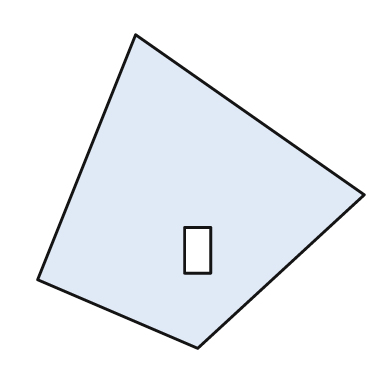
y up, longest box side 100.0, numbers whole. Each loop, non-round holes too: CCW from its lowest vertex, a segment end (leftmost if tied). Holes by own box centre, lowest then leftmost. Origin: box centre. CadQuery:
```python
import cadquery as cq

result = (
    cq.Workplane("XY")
    .moveTo(-1.0, -48.0)
    .lineTo(50.0, -1.0)
    .lineTo(-20.0, 48.0)
    .lineTo(-50.0, -27.0)
    .close()
    .moveTo(-5.0, -25.0)
    .lineTo(3.0, -25.0)
    .lineTo(3.0, -11.0)
    .lineTo(-5.0, -11.0)
    .close()
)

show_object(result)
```